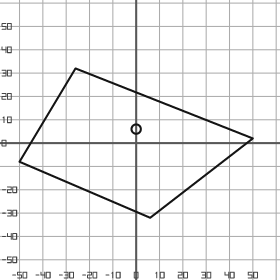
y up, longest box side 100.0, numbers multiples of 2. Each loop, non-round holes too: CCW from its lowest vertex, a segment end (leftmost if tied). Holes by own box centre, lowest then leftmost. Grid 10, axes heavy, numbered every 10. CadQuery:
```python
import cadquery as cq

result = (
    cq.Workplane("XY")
    .moveTo(6.0, -32.0)
    .lineTo(50.0, 2.0)
    .lineTo(-26.0, 32.0)
    .lineTo(-50.0, -8.0)
    .close()
    .moveTo(0.0, 6.0)
    .circle(2.0)
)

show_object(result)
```